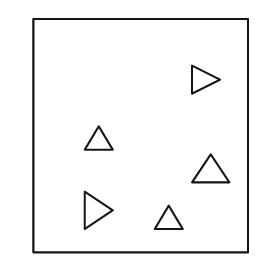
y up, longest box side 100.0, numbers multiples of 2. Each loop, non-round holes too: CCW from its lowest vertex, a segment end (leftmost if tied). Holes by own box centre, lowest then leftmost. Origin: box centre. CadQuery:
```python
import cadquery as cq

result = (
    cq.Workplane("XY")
    .moveTo(-46.0, -50.0)
    .lineTo(46.0, -50.0)
    .lineTo(46.0, 50.0)
    .lineTo(-46.0, 50.0)
    .close()
    .moveTo(6.0, -40.0)
    .lineTo(18.0, -40.0)
    .lineTo(12.0, -30.0)
    .close()
    .moveTo(-24.0, -40.0)
    .lineTo(-12.0, -32.0)
    .lineTo(-24.0, -24.0)
    .close()
    .moveTo(22.0, -20.0)
    .lineTo(38.0, -20.0)
    .lineTo(30.0, -8.0)
    .close()
    .moveTo(-24.0, -6.0)
    .lineTo(-12.0, -6.0)
    .lineTo(-18.0, 4.0)
    .close()
    .moveTo(22.0, 18.0)
    .lineTo(34.0, 24.0)
    .lineTo(22.0, 30.0)
    .close()
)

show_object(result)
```